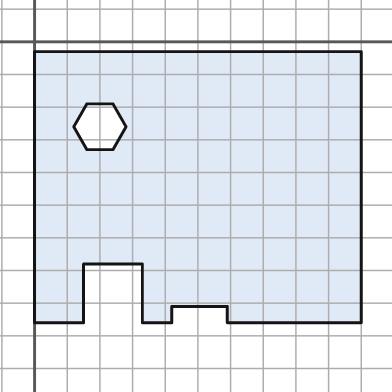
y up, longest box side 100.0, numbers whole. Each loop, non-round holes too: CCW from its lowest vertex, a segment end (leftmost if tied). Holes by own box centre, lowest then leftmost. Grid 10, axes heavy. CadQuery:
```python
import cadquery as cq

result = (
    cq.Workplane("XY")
    .moveTo(0.0, -86.0)
    .lineTo(15.0, -86.0)
    .lineTo(15.0, -68.0)
    .lineTo(33.0, -68.0)
    .lineTo(33.0, -86.0)
    .lineTo(42.0, -86.0)
    .lineTo(42.0, -81.0)
    .lineTo(59.0, -81.0)
    .lineTo(59.0, -86.0)
    .lineTo(100.0, -86.0)
    .lineTo(100.0, -3.0)
    .lineTo(0.0, -3.0)
    .close()
    .moveTo(16.0, -33.0)
    .lineTo(24.0, -33.0)
    .lineTo(28.0, -26.0)
    .lineTo(24.0, -19.0)
    .lineTo(16.0, -19.0)
    .lineTo(12.0, -26.0)
    .close()
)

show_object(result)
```